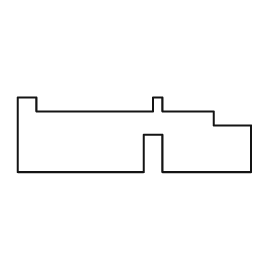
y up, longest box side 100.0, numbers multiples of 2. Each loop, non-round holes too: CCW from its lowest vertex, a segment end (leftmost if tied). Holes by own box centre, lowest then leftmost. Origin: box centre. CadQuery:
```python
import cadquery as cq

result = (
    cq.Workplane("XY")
    .moveTo(-50.0, -16.0)
    .lineTo(4.0, -16.0)
    .lineTo(4.0, 0.0)
    .lineTo(12.0, 0.0)
    .lineTo(12.0, -16.0)
    .lineTo(50.0, -16.0)
    .lineTo(50.0, 4.0)
    .lineTo(34.0, 4.0)
    .lineTo(34.0, 10.0)
    .lineTo(12.0, 10.0)
    .lineTo(12.0, 16.0)
    .lineTo(8.0, 16.0)
    .lineTo(8.0, 10.0)
    .lineTo(-42.0, 10.0)
    .lineTo(-42.0, 16.0)
    .lineTo(-50.0, 16.0)
    .close()
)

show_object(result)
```